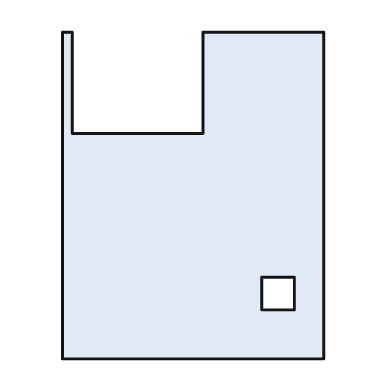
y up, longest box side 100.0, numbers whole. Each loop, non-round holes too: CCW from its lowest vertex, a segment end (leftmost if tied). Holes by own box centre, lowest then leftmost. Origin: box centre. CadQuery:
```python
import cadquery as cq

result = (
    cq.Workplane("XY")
    .moveTo(-40.0, -50.0)
    .lineTo(40.0, -50.0)
    .lineTo(40.0, 50.0)
    .lineTo(3.0, 50.0)
    .lineTo(3.0, 19.0)
    .lineTo(-37.0, 19.0)
    .lineTo(-37.0, 50.0)
    .lineTo(-40.0, 50.0)
    .close()
    .moveTo(21.0, -35.0)
    .lineTo(31.0, -35.0)
    .lineTo(31.0, -25.0)
    .lineTo(21.0, -25.0)
    .close()
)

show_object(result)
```